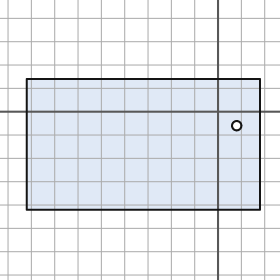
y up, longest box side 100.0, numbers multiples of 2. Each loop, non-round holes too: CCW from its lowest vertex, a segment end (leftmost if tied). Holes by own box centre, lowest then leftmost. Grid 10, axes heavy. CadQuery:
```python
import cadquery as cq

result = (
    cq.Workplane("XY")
    .moveTo(-82.0, -42.0)
    .lineTo(18.0, -42.0)
    .lineTo(18.0, 14.0)
    .lineTo(-82.0, 14.0)
    .close()
    .moveTo(8.0, -6.0)
    .circle(2.0)
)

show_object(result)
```